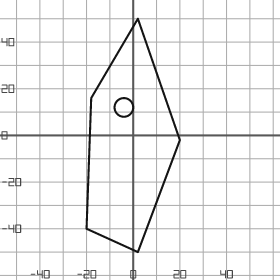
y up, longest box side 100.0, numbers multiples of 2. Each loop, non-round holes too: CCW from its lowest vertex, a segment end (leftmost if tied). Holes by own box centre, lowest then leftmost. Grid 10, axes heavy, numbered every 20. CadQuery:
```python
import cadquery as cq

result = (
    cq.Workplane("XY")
    .moveTo(2.0, -50.0)
    .lineTo(20.0, -2.0)
    .lineTo(2.0, 50.0)
    .lineTo(-18.0, 16.0)
    .lineTo(-20.0, -40.0)
    .close()
    .moveTo(-4.0, 12.0)
    .circle(4.0)
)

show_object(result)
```